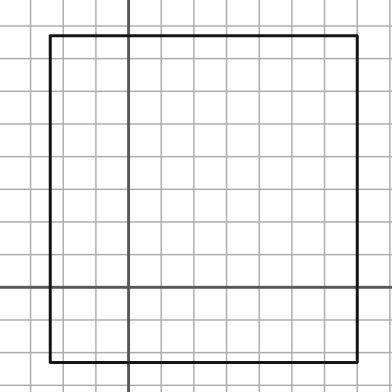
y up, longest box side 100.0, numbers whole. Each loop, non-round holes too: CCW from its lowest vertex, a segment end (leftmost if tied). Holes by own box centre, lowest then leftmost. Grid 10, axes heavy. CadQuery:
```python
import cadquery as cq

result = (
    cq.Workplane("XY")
    .moveTo(-24.0, -23.0)
    .lineTo(70.0, -23.0)
    .lineTo(70.0, 77.0)
    .lineTo(-24.0, 77.0)
    .close()
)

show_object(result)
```